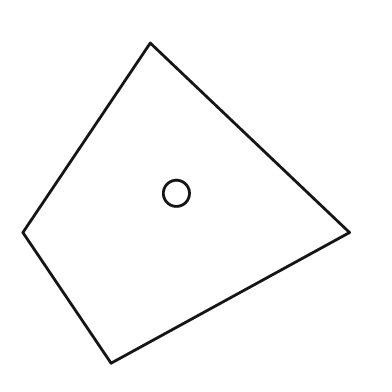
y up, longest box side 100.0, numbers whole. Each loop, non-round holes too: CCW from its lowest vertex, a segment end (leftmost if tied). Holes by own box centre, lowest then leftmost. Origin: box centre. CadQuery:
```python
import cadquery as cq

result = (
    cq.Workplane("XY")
    .moveTo(-23.0, -49.0)
    .lineTo(50.0, -9.0)
    .lineTo(-11.0, 49.0)
    .lineTo(-50.0, -9.0)
    .close()
    .moveTo(-3.0, 3.0)
    .circle(4.0)
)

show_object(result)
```